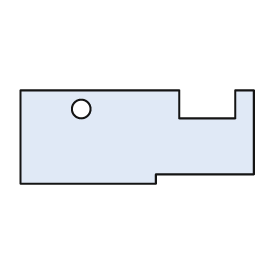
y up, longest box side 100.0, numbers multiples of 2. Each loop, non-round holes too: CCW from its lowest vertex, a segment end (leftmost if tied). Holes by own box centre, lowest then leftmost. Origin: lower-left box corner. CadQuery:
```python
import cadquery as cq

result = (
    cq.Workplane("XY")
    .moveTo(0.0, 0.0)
    .lineTo(58.0, 0.0)
    .lineTo(58.0, 4.0)
    .lineTo(100.0, 4.0)
    .lineTo(100.0, 40.0)
    .lineTo(92.0, 40.0)
    .lineTo(92.0, 28.0)
    .lineTo(68.0, 28.0)
    .lineTo(68.0, 40.0)
    .lineTo(0.0, 40.0)
    .close()
    .moveTo(26.0, 32.0)
    .circle(4.0)
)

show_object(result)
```